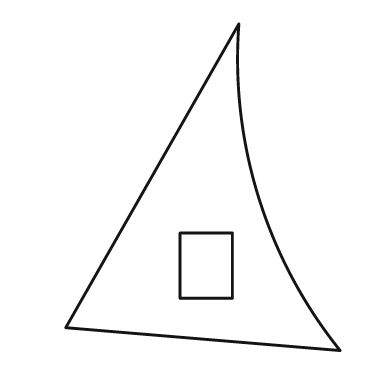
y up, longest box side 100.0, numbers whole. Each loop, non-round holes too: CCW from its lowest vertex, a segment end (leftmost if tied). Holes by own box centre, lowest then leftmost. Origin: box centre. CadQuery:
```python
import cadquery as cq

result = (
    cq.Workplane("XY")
    .moveTo(42.0, -50.0)
    .threePointArc((17.0, -3.0), (11.0, 50.0))
    .lineTo(-42.0, -43.0)
    .close()
    .moveTo(-7.0, -34.0)
    .lineTo(9.0, -34.0)
    .lineTo(9.0, -14.0)
    .lineTo(-7.0, -14.0)
    .close()
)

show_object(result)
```